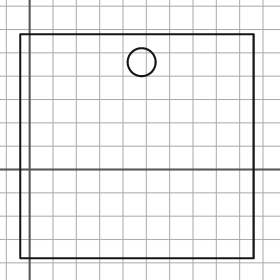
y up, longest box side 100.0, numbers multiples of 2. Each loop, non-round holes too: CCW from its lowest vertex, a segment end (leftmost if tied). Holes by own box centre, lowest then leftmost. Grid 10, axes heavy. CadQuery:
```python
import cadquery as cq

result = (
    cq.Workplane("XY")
    .moveTo(-4.0, -38.0)
    .lineTo(96.0, -38.0)
    .lineTo(96.0, 58.0)
    .lineTo(-4.0, 58.0)
    .close()
    .moveTo(48.0, 46.0)
    .circle(6.0)
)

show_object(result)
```